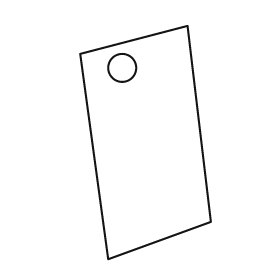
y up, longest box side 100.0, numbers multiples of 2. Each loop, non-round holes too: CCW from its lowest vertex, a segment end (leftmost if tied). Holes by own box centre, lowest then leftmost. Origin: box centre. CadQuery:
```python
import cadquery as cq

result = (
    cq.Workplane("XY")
    .moveTo(-16.0, -50.0)
    .lineTo(28.0, -34.0)
    .lineTo(18.0, 50.0)
    .lineTo(-28.0, 38.0)
    .close()
    .moveTo(-10.0, 32.0)
    .circle(6.0)
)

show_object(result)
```